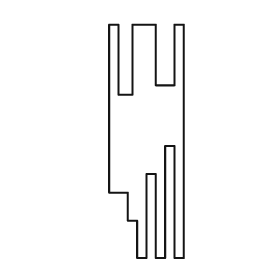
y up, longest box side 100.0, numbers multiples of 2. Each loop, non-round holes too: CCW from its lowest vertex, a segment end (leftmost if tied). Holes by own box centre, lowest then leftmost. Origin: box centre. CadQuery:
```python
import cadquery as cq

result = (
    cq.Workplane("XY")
    .moveTo(-4.0, -50.0)
    .lineTo(0.0, -50.0)
    .lineTo(0.0, -14.0)
    .lineTo(4.0, -14.0)
    .lineTo(4.0, -50.0)
    .lineTo(8.0, -50.0)
    .lineTo(8.0, -2.0)
    .lineTo(12.0, -2.0)
    .lineTo(12.0, -50.0)
    .lineTo(16.0, -50.0)
    .lineTo(16.0, 50.0)
    .lineTo(12.0, 50.0)
    .lineTo(12.0, 24.0)
    .lineTo(4.0, 24.0)
    .lineTo(4.0, 50.0)
    .lineTo(-6.0, 50.0)
    .lineTo(-6.0, 20.0)
    .lineTo(-12.0, 20.0)
    .lineTo(-12.0, 50.0)
    .lineTo(-16.0, 50.0)
    .lineTo(-16.0, -22.0)
    .lineTo(-8.0, -22.0)
    .lineTo(-8.0, -34.0)
    .lineTo(-4.0, -34.0)
    .close()
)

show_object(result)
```